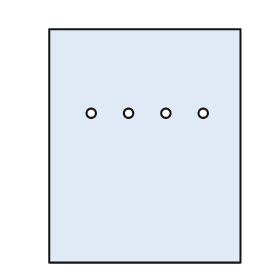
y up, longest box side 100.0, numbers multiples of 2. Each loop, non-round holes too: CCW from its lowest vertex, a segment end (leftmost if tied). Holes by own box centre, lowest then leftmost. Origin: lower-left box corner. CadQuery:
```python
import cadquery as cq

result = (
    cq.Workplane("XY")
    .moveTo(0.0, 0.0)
    .lineTo(82.0, 0.0)
    .lineTo(82.0, 100.0)
    .lineTo(0.0, 100.0)
    .close()
    .moveTo(18.0, 64.0)
    .circle(2.0)
    .moveTo(34.0, 64.0)
    .circle(2.0)
    .moveTo(50.0, 64.0)
    .circle(2.0)
    .moveTo(66.0, 64.0)
    .circle(2.0)
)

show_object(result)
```